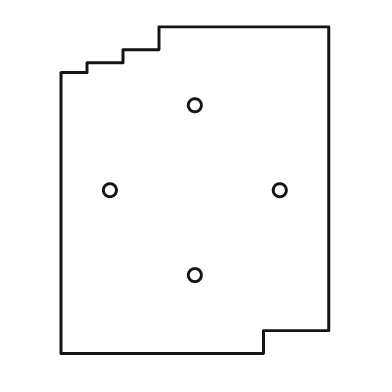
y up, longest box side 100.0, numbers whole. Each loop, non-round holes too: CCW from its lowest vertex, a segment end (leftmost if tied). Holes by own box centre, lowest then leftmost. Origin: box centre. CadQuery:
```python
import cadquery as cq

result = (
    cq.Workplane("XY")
    .moveTo(-41.0, -50.0)
    .lineTo(21.0, -50.0)
    .lineTo(21.0, -43.0)
    .lineTo(41.0, -43.0)
    .lineTo(41.0, 50.0)
    .lineTo(-11.0, 50.0)
    .lineTo(-11.0, 43.0)
    .lineTo(-22.0, 43.0)
    .lineTo(-22.0, 39.0)
    .lineTo(-33.0, 39.0)
    .lineTo(-33.0, 36.0)
    .lineTo(-41.0, 36.0)
    .close()
    .moveTo(0.0, -26.0)
    .circle(2.0)
    .moveTo(-26.0, 0.0)
    .circle(2.0)
    .moveTo(26.0, 0.0)
    .circle(2.0)
    .moveTo(0.0, 26.0)
    .circle(2.0)
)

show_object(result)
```